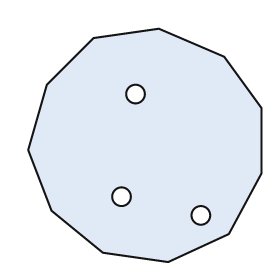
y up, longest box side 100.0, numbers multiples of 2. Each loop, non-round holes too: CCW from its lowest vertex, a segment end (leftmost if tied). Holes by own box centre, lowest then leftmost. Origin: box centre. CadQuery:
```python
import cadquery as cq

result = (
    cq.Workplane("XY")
    .moveTo(10.0, -50.0)
    .lineTo(36.0, -38.0)
    .lineTo(50.0, -12.0)
    .lineTo(50.0, 16.0)
    .lineTo(34.0, 38.0)
    .lineTo(6.0, 50.0)
    .lineTo(-22.0, 46.0)
    .lineTo(-42.0, 26.0)
    .lineTo(-50.0, -2.0)
    .lineTo(-40.0, -28.0)
    .lineTo(-18.0, -46.0)
    .close()
    .moveTo(24.0, -30.0)
    .circle(4.0)
    .moveTo(-10.0, -22.0)
    .circle(4.0)
    .moveTo(-4.0, 22.0)
    .circle(4.0)
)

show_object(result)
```